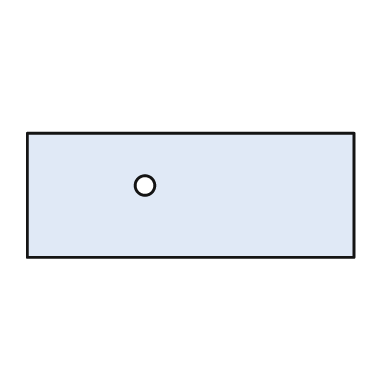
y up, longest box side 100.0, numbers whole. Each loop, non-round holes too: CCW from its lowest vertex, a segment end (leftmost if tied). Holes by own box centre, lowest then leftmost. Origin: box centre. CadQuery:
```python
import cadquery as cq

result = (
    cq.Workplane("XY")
    .moveTo(-50.0, -19.0)
    .lineTo(50.0, -19.0)
    .lineTo(50.0, 19.0)
    .lineTo(-50.0, 19.0)
    .close()
    .moveTo(-14.0, 3.0)
    .circle(3.0)
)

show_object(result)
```